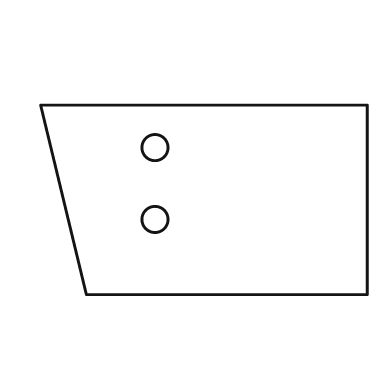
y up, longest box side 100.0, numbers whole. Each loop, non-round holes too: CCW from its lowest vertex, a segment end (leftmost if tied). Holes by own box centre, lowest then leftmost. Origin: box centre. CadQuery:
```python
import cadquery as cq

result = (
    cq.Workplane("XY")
    .moveTo(-36.0, -29.0)
    .lineTo(50.0, -29.0)
    .lineTo(50.0, 29.0)
    .lineTo(-50.0, 29.0)
    .close()
    .moveTo(-15.0, -6.0)
    .circle(4.0)
    .moveTo(-15.0, 16.0)
    .circle(4.0)
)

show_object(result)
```